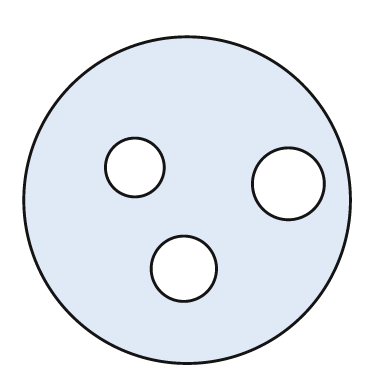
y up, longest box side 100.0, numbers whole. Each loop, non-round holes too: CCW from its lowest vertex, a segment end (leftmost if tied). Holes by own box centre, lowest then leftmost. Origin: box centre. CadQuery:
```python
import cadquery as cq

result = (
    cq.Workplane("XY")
    .moveTo(0.0, 0.0)
    .circle(50.0)
    .moveTo(-1.0, -21.0)
    .circle(10.0)
    .moveTo(31.0, 5.0)
    .circle(11.0)
    .moveTo(-16.0, 10.0)
    .circle(9.0)
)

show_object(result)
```